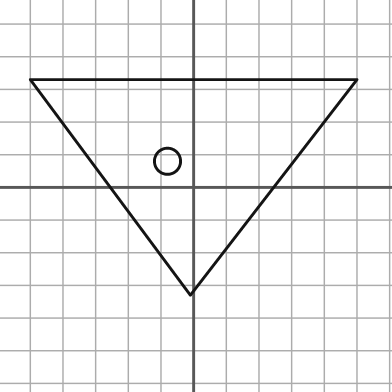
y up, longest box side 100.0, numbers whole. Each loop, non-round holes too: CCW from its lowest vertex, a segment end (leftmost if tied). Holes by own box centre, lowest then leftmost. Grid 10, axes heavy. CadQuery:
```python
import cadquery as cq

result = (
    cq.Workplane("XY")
    .moveTo(-1.0, -33.0)
    .lineTo(50.0, 33.0)
    .lineTo(-50.0, 33.0)
    .close()
    .moveTo(-8.0, 8.0)
    .circle(4.0)
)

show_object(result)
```